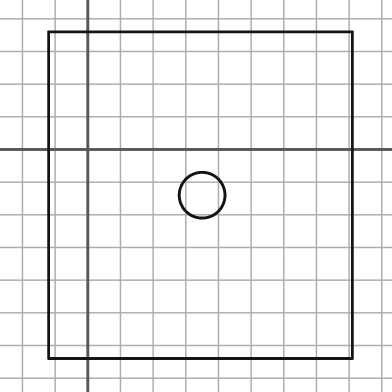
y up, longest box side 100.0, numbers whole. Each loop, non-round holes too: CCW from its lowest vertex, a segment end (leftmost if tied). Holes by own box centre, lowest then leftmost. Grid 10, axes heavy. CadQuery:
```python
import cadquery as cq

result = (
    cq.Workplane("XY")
    .moveTo(-12.0, -64.0)
    .lineTo(81.0, -64.0)
    .lineTo(81.0, 36.0)
    .lineTo(-12.0, 36.0)
    .close()
    .moveTo(35.0, -14.0)
    .circle(7.0)
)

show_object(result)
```